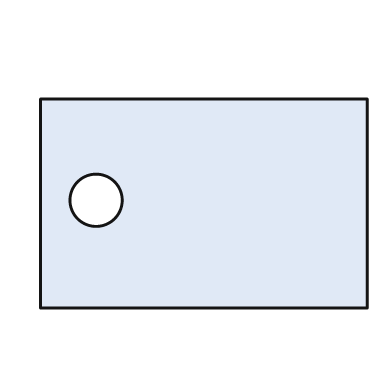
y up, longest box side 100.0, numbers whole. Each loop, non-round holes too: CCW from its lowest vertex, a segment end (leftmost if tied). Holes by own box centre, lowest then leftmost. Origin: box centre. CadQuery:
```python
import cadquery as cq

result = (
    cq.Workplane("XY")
    .moveTo(-50.0, -32.0)
    .lineTo(50.0, -32.0)
    .lineTo(50.0, 32.0)
    .lineTo(-50.0, 32.0)
    .close()
    .moveTo(-33.0, 1.0)
    .circle(8.0)
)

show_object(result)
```